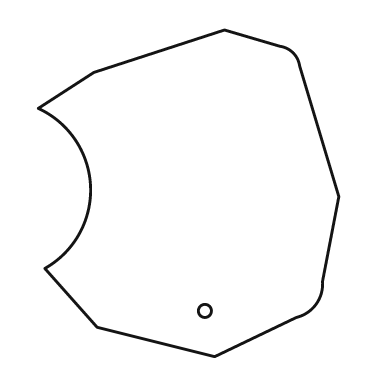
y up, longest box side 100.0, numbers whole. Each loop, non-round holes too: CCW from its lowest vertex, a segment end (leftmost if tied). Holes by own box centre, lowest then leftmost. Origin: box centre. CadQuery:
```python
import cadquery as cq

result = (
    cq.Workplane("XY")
    .moveTo(8.0, -50.0)
    .lineTo(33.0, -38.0)
    .threePointArc((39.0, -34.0), (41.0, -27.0))
    .lineTo(46.0, -1.0)
    .lineTo(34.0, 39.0)
    .threePointArc((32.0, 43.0), (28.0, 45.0))
    .lineTo(11.0, 50.0)
    .lineTo(-29.0, 37.0)
    .lineTo(-46.0, 26.0)
    .threePointArc((-30.0, 2.0), (-44.0, -23.0))
    .lineTo(-28.0, -41.0)
    .close()
    .moveTo(5.0, -36.0)
    .circle(2.0)
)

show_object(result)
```